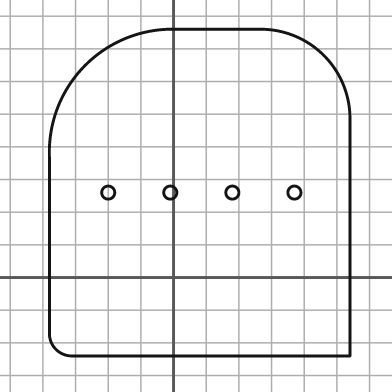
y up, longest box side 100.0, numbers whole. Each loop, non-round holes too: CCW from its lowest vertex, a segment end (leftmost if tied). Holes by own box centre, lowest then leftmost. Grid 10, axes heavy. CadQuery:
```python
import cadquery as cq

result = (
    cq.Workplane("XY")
    .moveTo(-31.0, -24.0)
    .lineTo(54.0, -24.0)
    .lineTo(54.0, 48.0)
    .threePointArc((46.0, 68.0), (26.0, 76.0))
    .lineTo(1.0, 76.0)
    .threePointArc((-27.0, 65.0), (-38.0, 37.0))
    .lineTo(-38.0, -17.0)
    .threePointArc((-36.0, -22.0), (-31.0, -24.0))
    .close()
    .moveTo(-20.0, 26.0)
    .circle(2.0)
    .moveTo(-1.0, 26.0)
    .circle(2.0)
    .moveTo(18.0, 26.0)
    .circle(2.0)
    .moveTo(37.0, 26.0)
    .circle(2.0)
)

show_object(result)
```